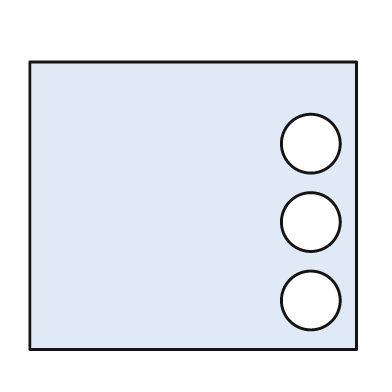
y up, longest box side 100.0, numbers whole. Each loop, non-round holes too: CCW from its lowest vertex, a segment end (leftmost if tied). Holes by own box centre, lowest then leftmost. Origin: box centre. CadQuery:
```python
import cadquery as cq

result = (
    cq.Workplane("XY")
    .moveTo(-50.0, -44.0)
    .lineTo(50.0, -44.0)
    .lineTo(50.0, 44.0)
    .lineTo(-50.0, 44.0)
    .close()
    .moveTo(36.0, -29.0)
    .circle(9.0)
    .moveTo(36.0, -5.0)
    .circle(9.0)
    .moveTo(36.0, 19.0)
    .circle(9.0)
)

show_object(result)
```